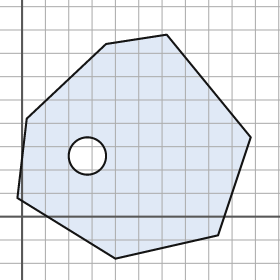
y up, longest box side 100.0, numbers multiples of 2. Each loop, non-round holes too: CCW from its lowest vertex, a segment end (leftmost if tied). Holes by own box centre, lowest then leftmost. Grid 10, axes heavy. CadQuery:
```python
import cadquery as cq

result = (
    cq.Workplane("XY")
    .moveTo(40.0, -18.0)
    .lineTo(84.0, -8.0)
    .lineTo(98.0, 34.0)
    .lineTo(62.0, 78.0)
    .lineTo(36.0, 74.0)
    .lineTo(2.0, 42.0)
    .lineTo(-2.0, 8.0)
    .close()
    .moveTo(28.0, 26.0)
    .circle(8.0)
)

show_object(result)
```